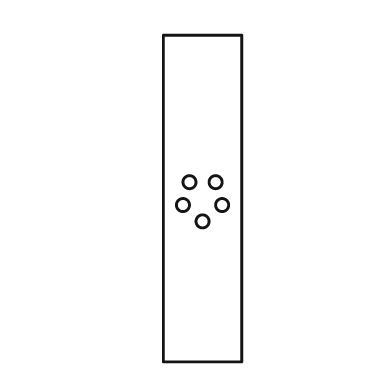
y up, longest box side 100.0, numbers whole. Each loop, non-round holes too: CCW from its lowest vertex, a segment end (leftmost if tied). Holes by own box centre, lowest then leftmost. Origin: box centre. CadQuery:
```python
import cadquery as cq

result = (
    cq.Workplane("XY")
    .moveTo(-12.0, -50.0)
    .lineTo(12.0, -50.0)
    .lineTo(12.0, 50.0)
    .lineTo(-12.0, 50.0)
    .close()
    .moveTo(0.0, -7.0)
    .circle(2.0)
    .moveTo(-6.0, -2.0)
    .circle(2.0)
    .moveTo(6.0, -2.0)
    .circle(2.0)
    .moveTo(-4.0, 5.0)
    .circle(2.0)
    .moveTo(4.0, 5.0)
    .circle(2.0)
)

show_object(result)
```